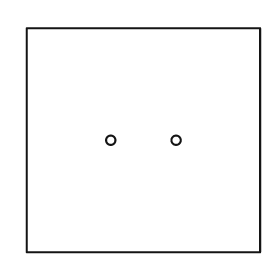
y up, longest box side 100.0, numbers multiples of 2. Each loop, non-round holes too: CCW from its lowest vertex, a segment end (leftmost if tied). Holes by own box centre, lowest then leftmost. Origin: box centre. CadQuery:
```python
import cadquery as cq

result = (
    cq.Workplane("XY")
    .moveTo(-50.0, -48.0)
    .lineTo(50.0, -48.0)
    .lineTo(50.0, 48.0)
    .lineTo(-50.0, 48.0)
    .close()
    .moveTo(-14.0, 0.0)
    .circle(2.0)
    .moveTo(14.0, 0.0)
    .circle(2.0)
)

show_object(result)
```